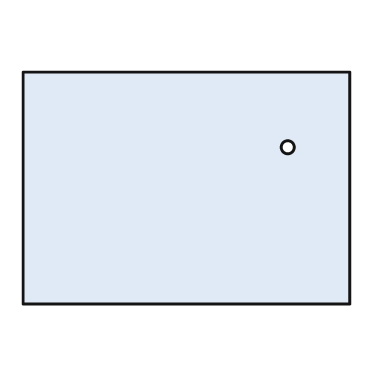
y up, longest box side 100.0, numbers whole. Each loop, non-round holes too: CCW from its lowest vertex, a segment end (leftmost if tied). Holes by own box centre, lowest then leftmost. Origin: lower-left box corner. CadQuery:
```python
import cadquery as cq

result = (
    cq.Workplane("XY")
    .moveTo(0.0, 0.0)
    .lineTo(100.0, 0.0)
    .lineTo(100.0, 71.0)
    .lineTo(0.0, 71.0)
    .close()
    .moveTo(81.0, 48.0)
    .circle(2.0)
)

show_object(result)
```